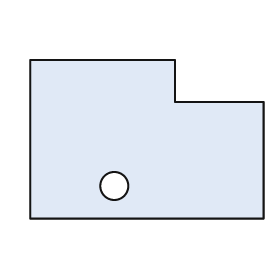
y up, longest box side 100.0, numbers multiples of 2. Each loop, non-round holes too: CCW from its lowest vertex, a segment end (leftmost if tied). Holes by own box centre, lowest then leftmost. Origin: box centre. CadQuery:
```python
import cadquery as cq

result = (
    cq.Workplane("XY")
    .moveTo(-50.0, -34.0)
    .lineTo(50.0, -34.0)
    .lineTo(50.0, 16.0)
    .lineTo(12.0, 16.0)
    .lineTo(12.0, 34.0)
    .lineTo(-50.0, 34.0)
    .close()
    .moveTo(-14.0, -20.0)
    .circle(6.0)
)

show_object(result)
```